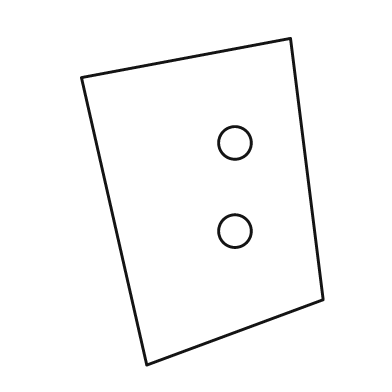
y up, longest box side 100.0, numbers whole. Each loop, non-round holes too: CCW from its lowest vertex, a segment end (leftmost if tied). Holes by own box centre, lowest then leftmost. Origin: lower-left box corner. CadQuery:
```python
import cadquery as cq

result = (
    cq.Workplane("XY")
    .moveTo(20.0, 0.0)
    .lineTo(74.0, 20.0)
    .lineTo(64.0, 100.0)
    .lineTo(0.0, 88.0)
    .close()
    .moveTo(47.0, 41.0)
    .circle(5.0)
    .moveTo(47.0, 68.0)
    .circle(5.0)
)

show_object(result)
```